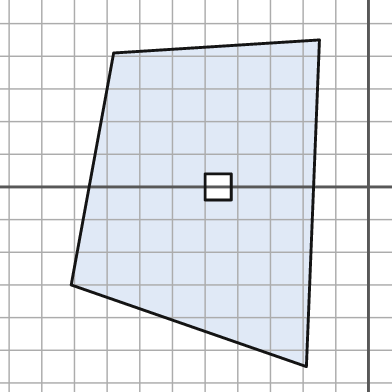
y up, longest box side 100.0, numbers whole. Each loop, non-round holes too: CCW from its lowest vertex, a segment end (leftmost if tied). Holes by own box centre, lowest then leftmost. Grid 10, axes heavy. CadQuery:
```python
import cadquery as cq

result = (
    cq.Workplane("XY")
    .moveTo(-19.0, -55.0)
    .lineTo(-15.0, 45.0)
    .lineTo(-78.0, 41.0)
    .lineTo(-91.0, -30.0)
    .close()
    .moveTo(-50.0, -4.0)
    .lineTo(-42.0, -4.0)
    .lineTo(-42.0, 4.0)
    .lineTo(-50.0, 4.0)
    .close()
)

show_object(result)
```